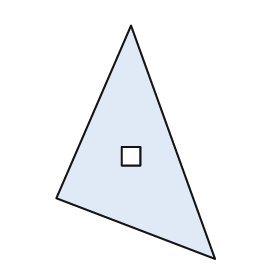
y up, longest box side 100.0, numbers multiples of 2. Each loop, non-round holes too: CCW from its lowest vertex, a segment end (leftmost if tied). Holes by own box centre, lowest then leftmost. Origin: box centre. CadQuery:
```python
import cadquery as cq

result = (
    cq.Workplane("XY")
    .moveTo(34.0, -50.0)
    .lineTo(-2.0, 50.0)
    .lineTo(-34.0, -24.0)
    .close()
    .moveTo(-6.0, -10.0)
    .lineTo(2.0, -10.0)
    .lineTo(2.0, -2.0)
    .lineTo(-6.0, -2.0)
    .close()
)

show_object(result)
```